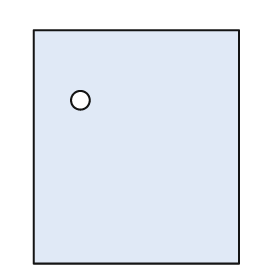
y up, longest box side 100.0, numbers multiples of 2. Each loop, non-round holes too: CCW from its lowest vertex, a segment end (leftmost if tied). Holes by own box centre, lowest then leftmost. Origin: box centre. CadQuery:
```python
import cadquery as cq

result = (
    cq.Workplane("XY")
    .moveTo(-44.0, -50.0)
    .lineTo(44.0, -50.0)
    .lineTo(44.0, 50.0)
    .lineTo(-44.0, 50.0)
    .close()
    .moveTo(-24.0, 20.0)
    .circle(4.0)
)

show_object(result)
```